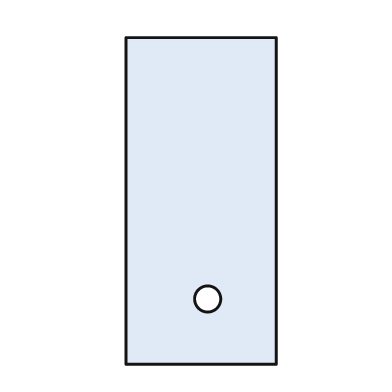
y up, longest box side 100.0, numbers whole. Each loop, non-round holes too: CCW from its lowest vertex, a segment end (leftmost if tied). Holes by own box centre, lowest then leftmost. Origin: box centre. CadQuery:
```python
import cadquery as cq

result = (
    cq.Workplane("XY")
    .moveTo(-23.0, -50.0)
    .lineTo(23.0, -50.0)
    .lineTo(23.0, 50.0)
    .lineTo(-23.0, 50.0)
    .close()
    .moveTo(2.0, -30.0)
    .circle(4.0)
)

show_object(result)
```